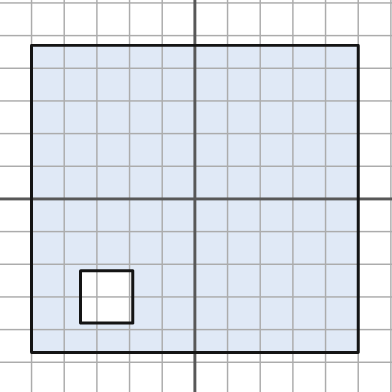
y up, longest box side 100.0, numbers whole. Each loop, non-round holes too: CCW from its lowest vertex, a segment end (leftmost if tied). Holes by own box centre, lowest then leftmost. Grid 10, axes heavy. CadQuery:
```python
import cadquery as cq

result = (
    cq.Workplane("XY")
    .moveTo(-50.0, -47.0)
    .lineTo(50.0, -47.0)
    .lineTo(50.0, 47.0)
    .lineTo(-50.0, 47.0)
    .close()
    .moveTo(-35.0, -38.0)
    .lineTo(-19.0, -38.0)
    .lineTo(-19.0, -22.0)
    .lineTo(-35.0, -22.0)
    .close()
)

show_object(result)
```